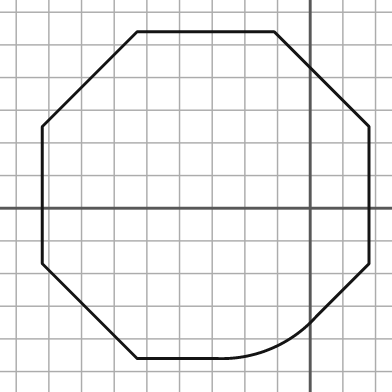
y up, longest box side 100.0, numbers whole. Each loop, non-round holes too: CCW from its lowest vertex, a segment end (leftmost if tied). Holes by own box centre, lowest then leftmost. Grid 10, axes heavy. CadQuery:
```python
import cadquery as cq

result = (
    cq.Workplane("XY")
    .moveTo(-53.0, -46.0)
    .lineTo(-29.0, -46.0)
    .threePointArc((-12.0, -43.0), (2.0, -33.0))
    .lineTo(18.0, -17.0)
    .lineTo(18.0, 25.0)
    .lineTo(-11.0, 54.0)
    .lineTo(-53.0, 54.0)
    .lineTo(-82.0, 25.0)
    .lineTo(-82.0, -17.0)
    .close()
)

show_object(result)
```